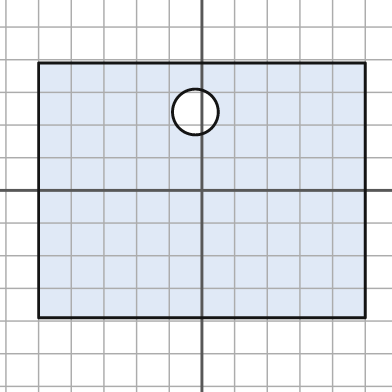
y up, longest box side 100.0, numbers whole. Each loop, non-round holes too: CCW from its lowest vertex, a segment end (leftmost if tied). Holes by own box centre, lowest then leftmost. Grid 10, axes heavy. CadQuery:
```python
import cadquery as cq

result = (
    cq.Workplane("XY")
    .moveTo(-50.0, -39.0)
    .lineTo(50.0, -39.0)
    .lineTo(50.0, 39.0)
    .lineTo(-50.0, 39.0)
    .close()
    .moveTo(-2.0, 24.0)
    .circle(7.0)
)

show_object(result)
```